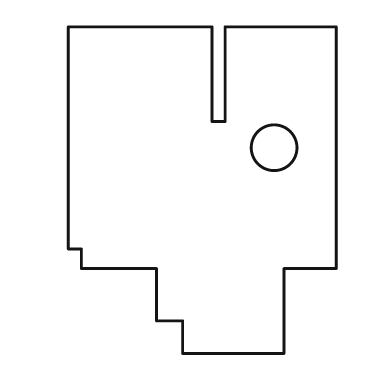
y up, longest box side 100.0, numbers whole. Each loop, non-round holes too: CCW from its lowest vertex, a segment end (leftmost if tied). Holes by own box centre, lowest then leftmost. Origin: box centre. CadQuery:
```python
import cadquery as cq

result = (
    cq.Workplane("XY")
    .moveTo(-6.0, -50.0)
    .lineTo(25.0, -50.0)
    .lineTo(25.0, -24.0)
    .lineTo(41.0, -24.0)
    .lineTo(41.0, 50.0)
    .lineTo(7.0, 50.0)
    .lineTo(7.0, 21.0)
    .lineTo(3.0, 21.0)
    .lineTo(3.0, 50.0)
    .lineTo(-41.0, 50.0)
    .lineTo(-41.0, -18.0)
    .lineTo(-37.0, -18.0)
    .lineTo(-37.0, -24.0)
    .lineTo(-14.0, -24.0)
    .lineTo(-14.0, -40.0)
    .lineTo(-6.0, -40.0)
    .close()
    .moveTo(22.0, 13.0)
    .circle(7.0)
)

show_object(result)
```